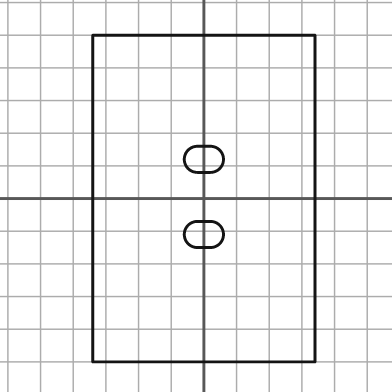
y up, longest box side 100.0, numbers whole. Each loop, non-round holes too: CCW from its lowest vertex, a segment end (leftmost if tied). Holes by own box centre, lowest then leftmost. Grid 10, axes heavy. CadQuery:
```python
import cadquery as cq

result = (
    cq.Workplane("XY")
    .moveTo(-34.0, -50.0)
    .lineTo(34.0, -50.0)
    .lineTo(34.0, 50.0)
    .lineTo(-34.0, 50.0)
    .close()
    .moveTo(-2.0, -15.0)
    .lineTo(2.0, -15.0)
    .threePointArc((6.0, -11.0), (2.0, -7.0))
    .lineTo(-2.0, -7.0)
    .threePointArc((-6.0, -11.0), (-2.0, -15.0))
    .close()
    .moveTo(-2.0, 8.0)
    .lineTo(2.0, 8.0)
    .threePointArc((6.0, 12.0), (2.0, 16.0))
    .lineTo(-2.0, 16.0)
    .threePointArc((-6.0, 12.0), (-2.0, 8.0))
    .close()
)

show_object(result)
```